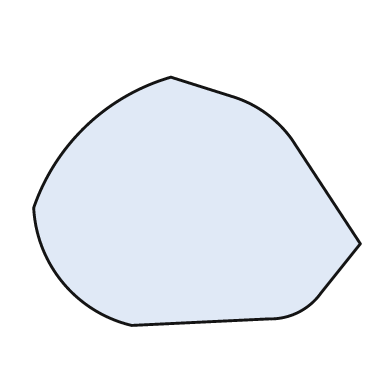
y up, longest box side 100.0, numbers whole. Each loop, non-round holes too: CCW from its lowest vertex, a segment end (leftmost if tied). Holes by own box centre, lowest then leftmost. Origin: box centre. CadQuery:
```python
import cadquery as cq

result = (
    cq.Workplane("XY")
    .moveTo(-20.0, -38.0)
    .lineTo(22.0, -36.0)
    .threePointArc((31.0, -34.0), (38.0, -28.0))
    .lineTo(50.0, -13.0)
    .lineTo(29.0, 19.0)
    .threePointArc((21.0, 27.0), (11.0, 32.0))
    .lineTo(-8.0, 38.0)
    .threePointArc((-34.0, 23.0), (-50.0, -2.0))
    .threePointArc((-41.0, -25.0), (-20.0, -38.0))
    .close()
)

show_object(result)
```